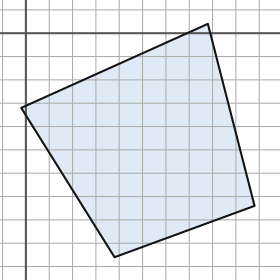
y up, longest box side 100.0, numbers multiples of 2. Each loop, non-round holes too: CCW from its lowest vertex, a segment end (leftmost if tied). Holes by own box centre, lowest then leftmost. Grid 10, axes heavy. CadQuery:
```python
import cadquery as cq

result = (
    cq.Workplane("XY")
    .moveTo(38.0, -96.0)
    .lineTo(98.0, -74.0)
    .lineTo(78.0, 4.0)
    .lineTo(-2.0, -32.0)
    .close()
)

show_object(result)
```